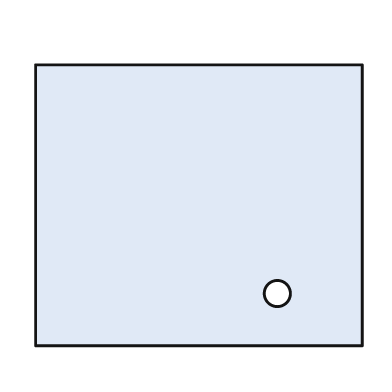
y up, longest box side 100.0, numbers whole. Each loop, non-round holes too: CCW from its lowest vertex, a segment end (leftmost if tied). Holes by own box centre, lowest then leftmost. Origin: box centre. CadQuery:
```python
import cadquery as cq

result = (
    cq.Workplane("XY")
    .moveTo(-50.0, -43.0)
    .lineTo(50.0, -43.0)
    .lineTo(50.0, 43.0)
    .lineTo(-50.0, 43.0)
    .close()
    .moveTo(24.0, -27.0)
    .circle(4.0)
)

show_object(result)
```